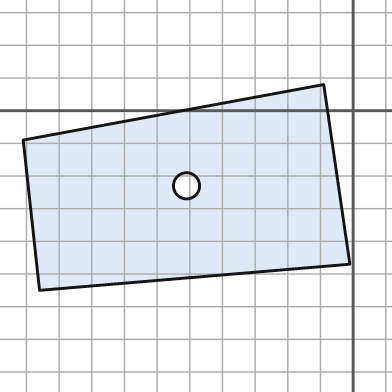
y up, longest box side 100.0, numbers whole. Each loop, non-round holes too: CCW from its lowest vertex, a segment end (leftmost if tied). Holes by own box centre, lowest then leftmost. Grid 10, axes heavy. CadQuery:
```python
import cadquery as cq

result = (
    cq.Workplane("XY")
    .moveTo(-96.0, -55.0)
    .lineTo(-1.0, -47.0)
    .lineTo(-9.0, 8.0)
    .lineTo(-101.0, -9.0)
    .close()
    .moveTo(-51.0, -23.0)
    .circle(4.0)
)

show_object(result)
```